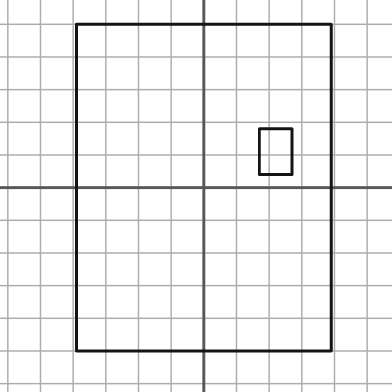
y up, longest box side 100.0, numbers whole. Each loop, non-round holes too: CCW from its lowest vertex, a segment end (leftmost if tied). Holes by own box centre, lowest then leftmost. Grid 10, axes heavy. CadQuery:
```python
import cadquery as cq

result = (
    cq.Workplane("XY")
    .moveTo(-39.0, -50.0)
    .lineTo(39.0, -50.0)
    .lineTo(39.0, 50.0)
    .lineTo(-39.0, 50.0)
    .close()
    .moveTo(17.0, 4.0)
    .lineTo(27.0, 4.0)
    .lineTo(27.0, 18.0)
    .lineTo(17.0, 18.0)
    .close()
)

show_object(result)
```